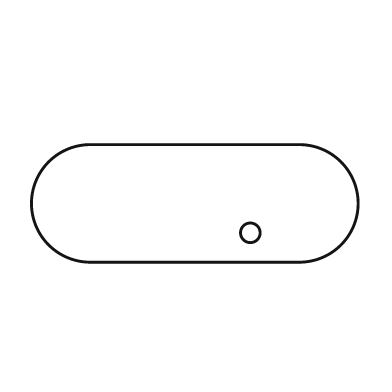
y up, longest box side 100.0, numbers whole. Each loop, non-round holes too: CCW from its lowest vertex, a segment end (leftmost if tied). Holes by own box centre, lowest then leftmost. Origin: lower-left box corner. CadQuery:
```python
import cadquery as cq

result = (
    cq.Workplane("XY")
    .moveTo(18.0, 0.0)
    .lineTo(82.0, 0.0)
    .threePointArc((100.0, 18.0), (82.0, 36.0))
    .lineTo(18.0, 36.0)
    .threePointArc((0.0, 18.0), (18.0, 0.0))
    .close()
    .moveTo(67.0, 9.0)
    .circle(3.0)
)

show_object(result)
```